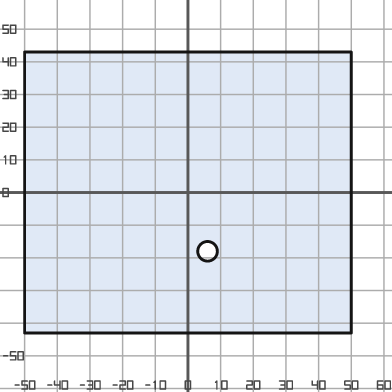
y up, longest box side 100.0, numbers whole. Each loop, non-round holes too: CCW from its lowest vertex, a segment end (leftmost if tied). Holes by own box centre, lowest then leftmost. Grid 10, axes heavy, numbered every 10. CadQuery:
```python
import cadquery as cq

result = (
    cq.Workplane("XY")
    .moveTo(-50.0, -43.0)
    .lineTo(50.0, -43.0)
    .lineTo(50.0, 43.0)
    .lineTo(-50.0, 43.0)
    .close()
    .moveTo(6.0, -18.0)
    .circle(3.0)
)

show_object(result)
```